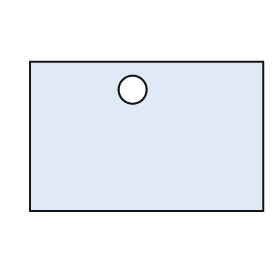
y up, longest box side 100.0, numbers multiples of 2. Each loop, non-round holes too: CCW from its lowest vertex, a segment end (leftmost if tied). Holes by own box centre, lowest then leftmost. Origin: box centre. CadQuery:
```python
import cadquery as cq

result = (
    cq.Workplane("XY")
    .moveTo(-50.0, -32.0)
    .lineTo(50.0, -32.0)
    .lineTo(50.0, 32.0)
    .lineTo(-50.0, 32.0)
    .close()
    .moveTo(-6.0, 20.0)
    .circle(6.0)
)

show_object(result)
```